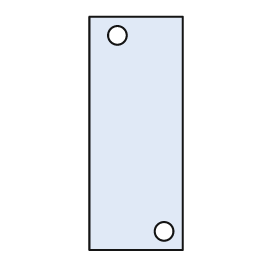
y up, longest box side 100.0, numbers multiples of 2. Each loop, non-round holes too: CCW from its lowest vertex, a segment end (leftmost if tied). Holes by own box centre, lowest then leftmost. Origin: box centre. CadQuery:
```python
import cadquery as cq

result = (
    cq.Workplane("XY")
    .moveTo(-20.0, -50.0)
    .lineTo(20.0, -50.0)
    .lineTo(20.0, 50.0)
    .lineTo(-20.0, 50.0)
    .close()
    .moveTo(12.0, -42.0)
    .circle(4.0)
    .moveTo(-8.0, 42.0)
    .circle(4.0)
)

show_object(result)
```